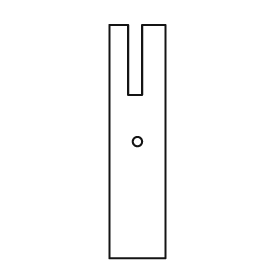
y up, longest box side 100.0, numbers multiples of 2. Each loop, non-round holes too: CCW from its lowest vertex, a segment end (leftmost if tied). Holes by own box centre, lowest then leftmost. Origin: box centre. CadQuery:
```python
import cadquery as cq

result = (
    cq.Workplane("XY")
    .moveTo(-12.0, -50.0)
    .lineTo(12.0, -50.0)
    .lineTo(12.0, 50.0)
    .lineTo(2.0, 50.0)
    .lineTo(2.0, 20.0)
    .lineTo(-4.0, 20.0)
    .lineTo(-4.0, 50.0)
    .lineTo(-12.0, 50.0)
    .close()
    .moveTo(0.0, 0.0)
    .circle(2.0)
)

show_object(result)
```